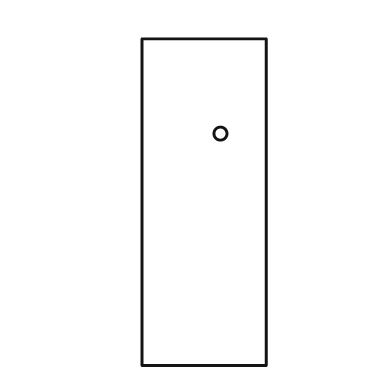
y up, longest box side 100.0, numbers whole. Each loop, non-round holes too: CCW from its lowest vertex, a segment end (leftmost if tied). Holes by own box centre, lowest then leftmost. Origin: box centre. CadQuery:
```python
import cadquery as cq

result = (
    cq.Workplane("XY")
    .moveTo(-19.0, -50.0)
    .lineTo(19.0, -50.0)
    .lineTo(19.0, 50.0)
    .lineTo(-19.0, 50.0)
    .close()
    .moveTo(5.0, 21.0)
    .circle(2.0)
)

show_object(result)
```